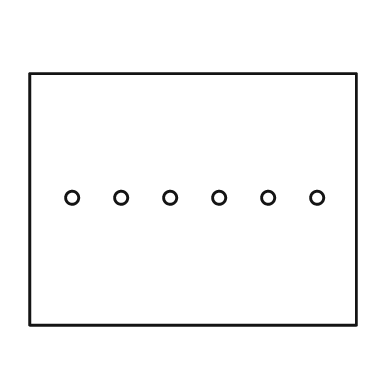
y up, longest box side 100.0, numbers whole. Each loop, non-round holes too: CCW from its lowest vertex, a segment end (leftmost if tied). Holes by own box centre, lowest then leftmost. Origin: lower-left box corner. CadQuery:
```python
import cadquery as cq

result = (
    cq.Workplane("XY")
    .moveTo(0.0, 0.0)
    .lineTo(100.0, 0.0)
    .lineTo(100.0, 77.0)
    .lineTo(0.0, 77.0)
    .close()
    .moveTo(13.0, 39.0)
    .circle(2.0)
    .moveTo(28.0, 39.0)
    .circle(2.0)
    .moveTo(43.0, 39.0)
    .circle(2.0)
    .moveTo(58.0, 39.0)
    .circle(2.0)
    .moveTo(73.0, 39.0)
    .circle(2.0)
    .moveTo(88.0, 39.0)
    .circle(2.0)
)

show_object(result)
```